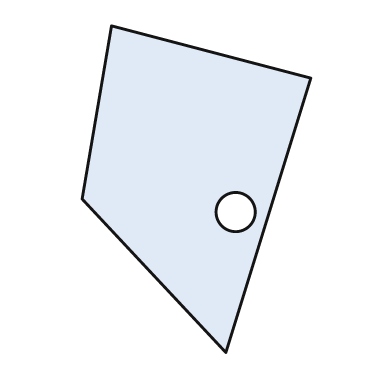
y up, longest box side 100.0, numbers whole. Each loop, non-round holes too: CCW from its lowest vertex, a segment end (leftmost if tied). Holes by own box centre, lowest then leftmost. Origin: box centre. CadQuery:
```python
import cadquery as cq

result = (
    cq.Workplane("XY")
    .moveTo(9.0, -50.0)
    .lineTo(35.0, 34.0)
    .lineTo(-26.0, 50.0)
    .lineTo(-35.0, -3.0)
    .close()
    .moveTo(12.0, -7.0)
    .circle(6.0)
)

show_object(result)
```